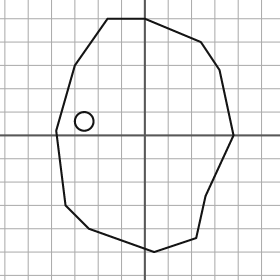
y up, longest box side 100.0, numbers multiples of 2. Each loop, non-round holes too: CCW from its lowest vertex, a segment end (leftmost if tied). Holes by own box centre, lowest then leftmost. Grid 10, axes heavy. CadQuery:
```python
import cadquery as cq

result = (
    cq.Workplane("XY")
    .moveTo(4.0, -50.0)
    .lineTo(22.0, -44.0)
    .lineTo(26.0, -26.0)
    .lineTo(38.0, 0.0)
    .lineTo(32.0, 28.0)
    .lineTo(24.0, 40.0)
    .lineTo(0.0, 50.0)
    .lineTo(-16.0, 50.0)
    .lineTo(-30.0, 30.0)
    .lineTo(-38.0, 2.0)
    .lineTo(-34.0, -30.0)
    .lineTo(-24.0, -40.0)
    .close()
    .moveTo(-26.0, 6.0)
    .circle(4.0)
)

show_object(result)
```